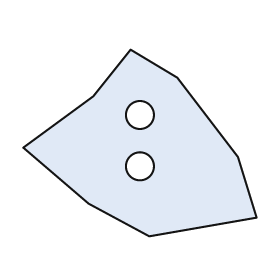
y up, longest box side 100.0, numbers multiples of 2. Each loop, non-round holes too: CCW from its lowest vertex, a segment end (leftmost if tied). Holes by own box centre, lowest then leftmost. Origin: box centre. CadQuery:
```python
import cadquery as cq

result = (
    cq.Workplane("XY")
    .moveTo(4.0, -40.0)
    .lineTo(50.0, -32.0)
    .lineTo(42.0, -6.0)
    .lineTo(16.0, 28.0)
    .lineTo(-4.0, 40.0)
    .lineTo(-20.0, 20.0)
    .lineTo(-50.0, -2.0)
    .lineTo(-22.0, -26.0)
    .close()
    .moveTo(0.0, -10.0)
    .circle(6.0)
    .moveTo(0.0, 12.0)
    .circle(6.0)
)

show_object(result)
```